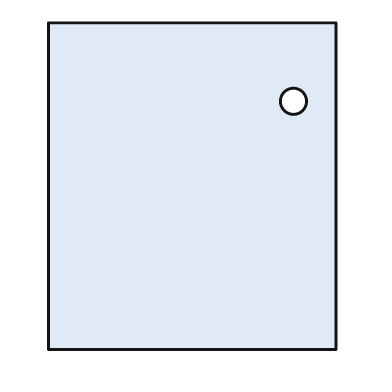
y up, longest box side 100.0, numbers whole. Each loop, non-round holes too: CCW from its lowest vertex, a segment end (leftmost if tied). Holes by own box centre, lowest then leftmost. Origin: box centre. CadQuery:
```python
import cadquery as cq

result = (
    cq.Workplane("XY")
    .moveTo(-44.0, -50.0)
    .lineTo(44.0, -50.0)
    .lineTo(44.0, 50.0)
    .lineTo(-44.0, 50.0)
    .close()
    .moveTo(31.0, 26.0)
    .circle(4.0)
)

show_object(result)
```